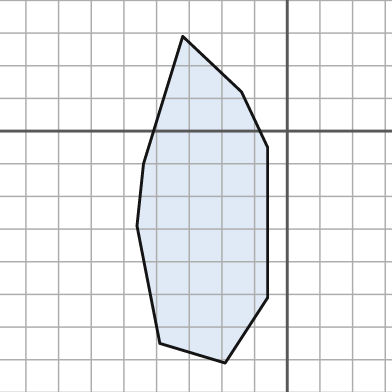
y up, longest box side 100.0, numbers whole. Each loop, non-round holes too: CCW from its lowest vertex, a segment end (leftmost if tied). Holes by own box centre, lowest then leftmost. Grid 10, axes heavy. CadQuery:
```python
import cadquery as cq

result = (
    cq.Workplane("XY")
    .moveTo(-19.0, -71.0)
    .lineTo(-6.0, -51.0)
    .lineTo(-6.0, -5.0)
    .lineTo(-14.0, 12.0)
    .lineTo(-32.0, 29.0)
    .lineTo(-44.0, -10.0)
    .lineTo(-46.0, -29.0)
    .lineTo(-39.0, -65.0)
    .close()
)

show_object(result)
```